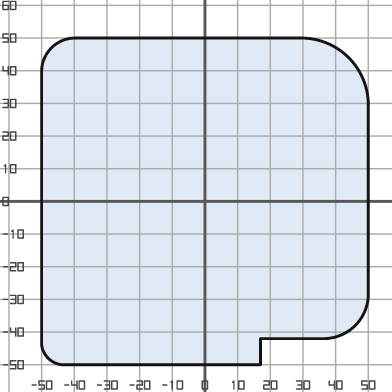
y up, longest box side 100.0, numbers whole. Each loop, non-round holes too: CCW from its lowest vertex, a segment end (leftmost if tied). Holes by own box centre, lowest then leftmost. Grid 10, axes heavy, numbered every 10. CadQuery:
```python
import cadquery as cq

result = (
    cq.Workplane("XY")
    .moveTo(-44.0, -50.0)
    .lineTo(17.0, -50.0)
    .lineTo(17.0, -42.0)
    .lineTo(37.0, -42.0)
    .threePointArc((46.0, -38.0), (50.0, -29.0))
    .lineTo(50.0, 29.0)
    .threePointArc((44.0, 44.0), (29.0, 50.0))
    .lineTo(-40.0, 50.0)
    .threePointArc((-47.0, 47.0), (-50.0, 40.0))
    .lineTo(-50.0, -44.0)
    .threePointArc((-48.0, -48.0), (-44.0, -50.0))
    .close()
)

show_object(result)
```